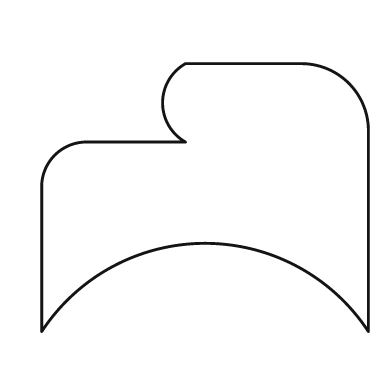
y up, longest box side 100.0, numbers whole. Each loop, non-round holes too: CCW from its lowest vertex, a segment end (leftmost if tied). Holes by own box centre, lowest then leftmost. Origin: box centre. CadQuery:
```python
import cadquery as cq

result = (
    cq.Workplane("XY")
    .moveTo(-50.0, -41.0)
    .threePointArc((0.0, -14.0), (50.0, -41.0))
    .lineTo(50.0, 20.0)
    .threePointArc((44.0, 35.0), (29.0, 41.0))
    .lineTo(-6.0, 41.0)
    .threePointArc((-13.0, 29.0), (-6.0, 17.0))
    .lineTo(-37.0, 17.0)
    .threePointArc((-46.0, 13.0), (-50.0, 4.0))
    .close()
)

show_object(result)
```